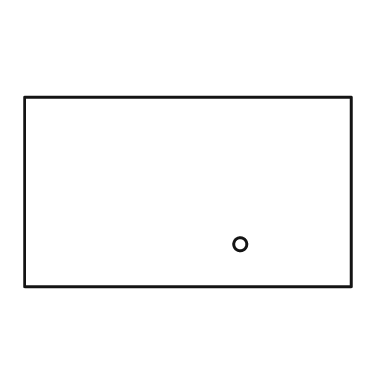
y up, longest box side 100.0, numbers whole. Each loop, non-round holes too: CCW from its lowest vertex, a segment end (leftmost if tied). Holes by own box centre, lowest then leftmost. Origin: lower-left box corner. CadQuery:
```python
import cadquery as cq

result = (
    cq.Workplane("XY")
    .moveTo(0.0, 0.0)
    .lineTo(100.0, 0.0)
    .lineTo(100.0, 58.0)
    .lineTo(0.0, 58.0)
    .close()
    .moveTo(66.0, 13.0)
    .circle(2.0)
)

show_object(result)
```